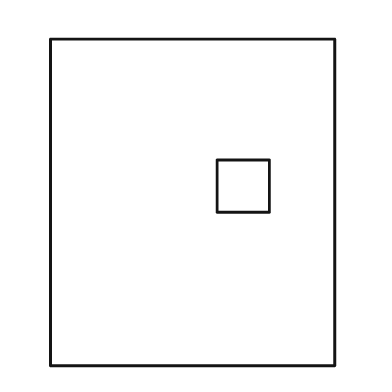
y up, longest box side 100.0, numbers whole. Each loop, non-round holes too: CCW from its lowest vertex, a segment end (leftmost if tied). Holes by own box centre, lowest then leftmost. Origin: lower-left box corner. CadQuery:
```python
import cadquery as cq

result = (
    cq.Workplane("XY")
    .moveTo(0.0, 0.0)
    .lineTo(87.0, 0.0)
    .lineTo(87.0, 100.0)
    .lineTo(0.0, 100.0)
    .close()
    .moveTo(51.0, 47.0)
    .lineTo(67.0, 47.0)
    .lineTo(67.0, 63.0)
    .lineTo(51.0, 63.0)
    .close()
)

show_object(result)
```